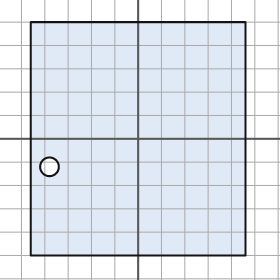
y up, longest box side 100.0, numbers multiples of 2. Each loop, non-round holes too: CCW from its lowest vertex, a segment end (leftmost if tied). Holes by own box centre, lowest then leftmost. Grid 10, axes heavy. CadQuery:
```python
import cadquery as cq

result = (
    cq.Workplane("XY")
    .moveTo(-46.0, -50.0)
    .lineTo(46.0, -50.0)
    .lineTo(46.0, 50.0)
    .lineTo(-46.0, 50.0)
    .close()
    .moveTo(-38.0, -12.0)
    .circle(4.0)
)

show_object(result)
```